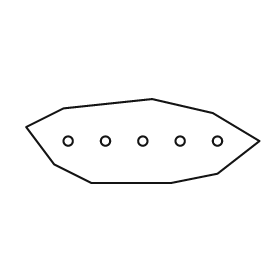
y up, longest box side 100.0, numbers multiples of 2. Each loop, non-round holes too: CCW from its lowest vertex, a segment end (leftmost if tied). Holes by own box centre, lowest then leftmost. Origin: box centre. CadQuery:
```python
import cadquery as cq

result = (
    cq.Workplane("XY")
    .moveTo(-22.0, -18.0)
    .lineTo(12.0, -18.0)
    .lineTo(32.0, -14.0)
    .lineTo(50.0, 0.0)
    .lineTo(30.0, 12.0)
    .lineTo(4.0, 18.0)
    .lineTo(-34.0, 14.0)
    .lineTo(-50.0, 6.0)
    .lineTo(-38.0, -10.0)
    .close()
    .moveTo(-32.0, 0.0)
    .circle(2.0)
    .moveTo(-16.0, 0.0)
    .circle(2.0)
    .moveTo(0.0, 0.0)
    .circle(2.0)
    .moveTo(16.0, 0.0)
    .circle(2.0)
    .moveTo(32.0, 0.0)
    .circle(2.0)
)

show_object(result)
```